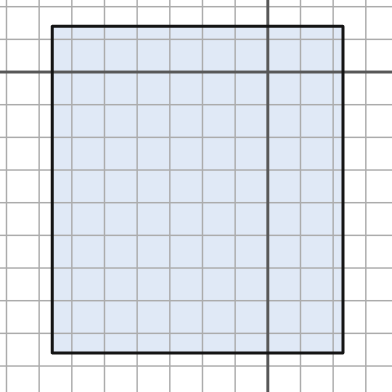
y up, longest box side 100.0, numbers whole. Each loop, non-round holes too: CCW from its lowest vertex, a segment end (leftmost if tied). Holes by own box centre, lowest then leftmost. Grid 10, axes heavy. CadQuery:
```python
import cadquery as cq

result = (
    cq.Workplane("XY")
    .moveTo(-66.0, -86.0)
    .lineTo(23.0, -86.0)
    .lineTo(23.0, 14.0)
    .lineTo(-66.0, 14.0)
    .close()
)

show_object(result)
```